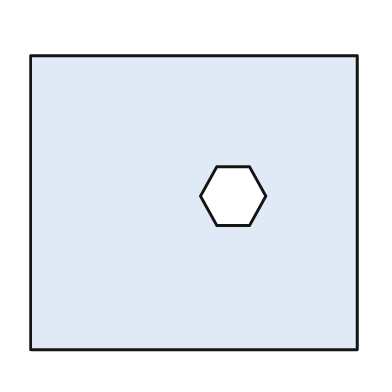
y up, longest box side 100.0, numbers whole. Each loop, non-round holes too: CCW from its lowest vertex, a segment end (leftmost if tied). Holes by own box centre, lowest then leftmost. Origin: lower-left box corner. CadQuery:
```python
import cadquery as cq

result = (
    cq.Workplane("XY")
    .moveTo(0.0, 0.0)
    .lineTo(100.0, 0.0)
    .lineTo(100.0, 90.0)
    .lineTo(0.0, 90.0)
    .close()
    .moveTo(57.0, 38.0)
    .lineTo(67.0, 38.0)
    .lineTo(72.0, 47.0)
    .lineTo(67.0, 56.0)
    .lineTo(57.0, 56.0)
    .lineTo(52.0, 47.0)
    .close()
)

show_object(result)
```